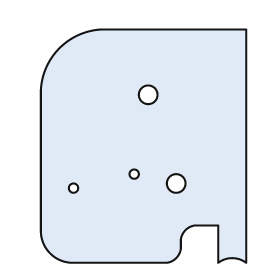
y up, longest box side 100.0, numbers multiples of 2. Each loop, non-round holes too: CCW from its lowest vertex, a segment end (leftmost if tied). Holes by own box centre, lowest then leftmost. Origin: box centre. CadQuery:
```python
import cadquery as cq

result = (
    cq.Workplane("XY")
    .moveTo(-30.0, -50.0)
    .lineTo(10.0, -50.0)
    .threePointArc((14.0, -48.0), (16.0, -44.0))
    .lineTo(16.0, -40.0)
    .threePointArc((18.0, -36.0), (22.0, -34.0))
    .lineTo(32.0, -34.0)
    .lineTo(32.0, -50.0)
    .threePointArc((38.0, -48.0), (44.0, -50.0))
    .lineTo(44.0, 50.0)
    .lineTo(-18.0, 50.0)
    .threePointArc((-36.0, 42.0), (-44.0, 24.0))
    .lineTo(-44.0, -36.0)
    .threePointArc((-40.0, -46.0), (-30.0, -50.0))
    .close()
    .moveTo(-30.0, -18.0)
    .circle(2.0)
    .moveTo(14.0, -16.0)
    .circle(4.0)
    .moveTo(-4.0, -12.0)
    .circle(2.0)
    .moveTo(2.0, 22.0)
    .circle(4.0)
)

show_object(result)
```